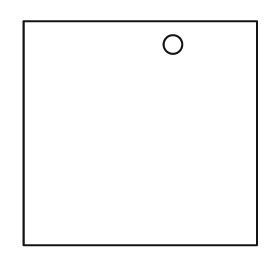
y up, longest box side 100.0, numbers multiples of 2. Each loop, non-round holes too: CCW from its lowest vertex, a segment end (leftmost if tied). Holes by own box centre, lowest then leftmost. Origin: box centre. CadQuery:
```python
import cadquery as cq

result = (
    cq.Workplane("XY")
    .moveTo(-50.0, -48.0)
    .lineTo(50.0, -48.0)
    .lineTo(50.0, 48.0)
    .lineTo(-50.0, 48.0)
    .close()
    .moveTo(14.0, 38.0)
    .circle(4.0)
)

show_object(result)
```